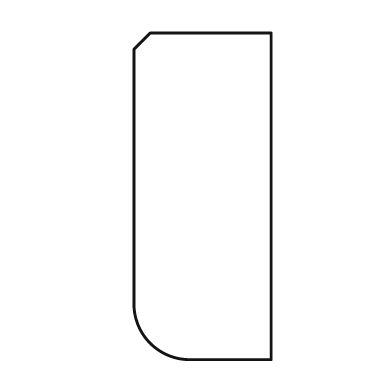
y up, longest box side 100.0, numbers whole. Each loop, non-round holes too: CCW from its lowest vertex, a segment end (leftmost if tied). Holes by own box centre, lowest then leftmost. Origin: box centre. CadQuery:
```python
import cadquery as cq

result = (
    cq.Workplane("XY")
    .moveTo(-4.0, -50.0)
    .lineTo(21.0, -50.0)
    .lineTo(21.0, 50.0)
    .lineTo(-16.0, 50.0)
    .lineTo(-21.0, 45.0)
    .lineTo(-21.0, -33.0)
    .threePointArc((-16.0, -45.0), (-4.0, -50.0))
    .close()
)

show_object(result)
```